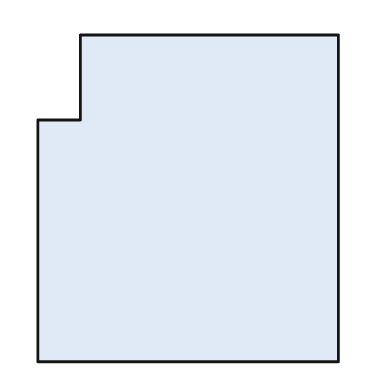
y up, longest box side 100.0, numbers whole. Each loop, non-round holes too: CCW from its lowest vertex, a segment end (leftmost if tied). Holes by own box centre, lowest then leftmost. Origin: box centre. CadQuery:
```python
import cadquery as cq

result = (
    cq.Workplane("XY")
    .moveTo(-46.0, -50.0)
    .lineTo(46.0, -50.0)
    .lineTo(46.0, 50.0)
    .lineTo(-33.0, 50.0)
    .lineTo(-33.0, 24.0)
    .lineTo(-46.0, 24.0)
    .close()
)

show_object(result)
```